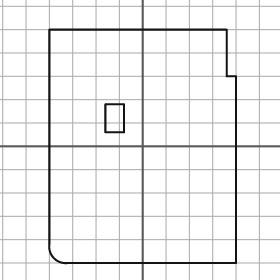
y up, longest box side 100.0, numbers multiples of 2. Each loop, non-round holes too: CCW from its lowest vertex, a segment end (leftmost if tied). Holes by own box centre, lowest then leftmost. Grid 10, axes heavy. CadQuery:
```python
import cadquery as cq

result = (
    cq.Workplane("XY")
    .moveTo(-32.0, -50.0)
    .lineTo(40.0, -50.0)
    .lineTo(40.0, 30.0)
    .lineTo(36.0, 30.0)
    .lineTo(36.0, 50.0)
    .lineTo(-40.0, 50.0)
    .lineTo(-40.0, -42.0)
    .threePointArc((-38.0, -48.0), (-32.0, -50.0))
    .close()
    .moveTo(-16.0, 6.0)
    .lineTo(-8.0, 6.0)
    .lineTo(-8.0, 18.0)
    .lineTo(-16.0, 18.0)
    .close()
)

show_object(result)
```